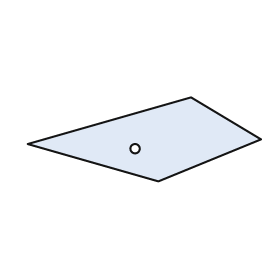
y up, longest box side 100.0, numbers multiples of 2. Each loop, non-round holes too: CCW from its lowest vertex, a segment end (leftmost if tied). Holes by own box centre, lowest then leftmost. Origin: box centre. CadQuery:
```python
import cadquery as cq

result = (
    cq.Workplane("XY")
    .moveTo(6.0, -18.0)
    .lineTo(50.0, 0.0)
    .lineTo(20.0, 18.0)
    .lineTo(-50.0, -2.0)
    .close()
    .moveTo(-4.0, -4.0)
    .circle(2.0)
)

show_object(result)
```